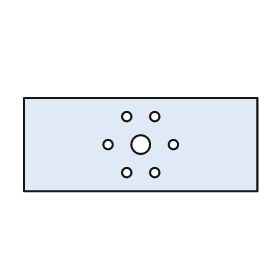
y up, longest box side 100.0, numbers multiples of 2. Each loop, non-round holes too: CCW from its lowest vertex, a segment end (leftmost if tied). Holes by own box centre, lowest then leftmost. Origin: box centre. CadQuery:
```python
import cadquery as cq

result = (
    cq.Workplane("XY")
    .moveTo(-50.0, -20.0)
    .lineTo(50.0, -20.0)
    .lineTo(50.0, 20.0)
    .lineTo(-50.0, 20.0)
    .close()
    .moveTo(-6.0, -12.0)
    .circle(2.0)
    .moveTo(6.0, -12.0)
    .circle(2.0)
    .moveTo(-14.0, 0.0)
    .circle(2.0)
    .moveTo(0.0, 0.0)
    .circle(4.0)
    .moveTo(14.0, 0.0)
    .circle(2.0)
    .moveTo(-6.0, 12.0)
    .circle(2.0)
    .moveTo(6.0, 12.0)
    .circle(2.0)
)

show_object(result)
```